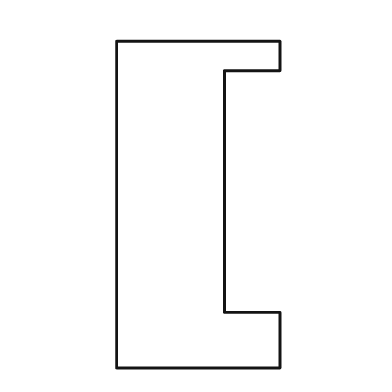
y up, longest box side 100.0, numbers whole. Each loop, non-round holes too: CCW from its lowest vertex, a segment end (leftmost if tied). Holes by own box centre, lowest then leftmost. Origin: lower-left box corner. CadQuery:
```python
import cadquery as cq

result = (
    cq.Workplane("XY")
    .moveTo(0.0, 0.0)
    .lineTo(50.0, 0.0)
    .lineTo(50.0, 17.0)
    .lineTo(33.0, 17.0)
    .lineTo(33.0, 91.0)
    .lineTo(50.0, 91.0)
    .lineTo(50.0, 100.0)
    .lineTo(0.0, 100.0)
    .close()
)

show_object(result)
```